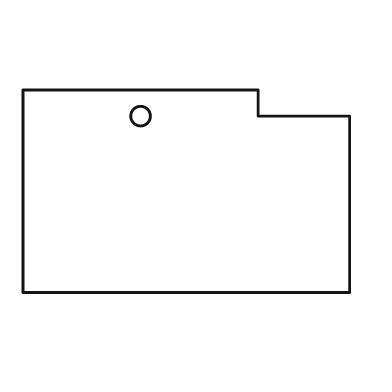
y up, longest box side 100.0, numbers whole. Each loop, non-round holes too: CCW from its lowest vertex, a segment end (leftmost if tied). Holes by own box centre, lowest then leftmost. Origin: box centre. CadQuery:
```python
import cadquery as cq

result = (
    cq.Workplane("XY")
    .moveTo(-50.0, -31.0)
    .lineTo(50.0, -31.0)
    .lineTo(50.0, 23.0)
    .lineTo(22.0, 23.0)
    .lineTo(22.0, 31.0)
    .lineTo(-50.0, 31.0)
    .close()
    .moveTo(-14.0, 23.0)
    .circle(3.0)
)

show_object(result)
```